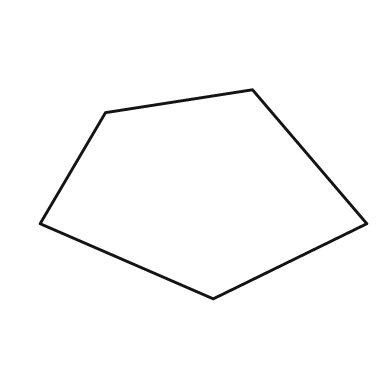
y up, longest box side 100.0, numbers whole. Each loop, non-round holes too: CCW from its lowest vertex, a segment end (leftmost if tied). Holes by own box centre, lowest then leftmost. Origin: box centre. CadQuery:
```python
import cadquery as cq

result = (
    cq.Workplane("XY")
    .moveTo(3.0, -32.0)
    .lineTo(50.0, -9.0)
    .lineTo(15.0, 32.0)
    .lineTo(-30.0, 25.0)
    .lineTo(-50.0, -9.0)
    .close()
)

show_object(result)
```